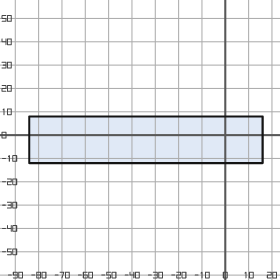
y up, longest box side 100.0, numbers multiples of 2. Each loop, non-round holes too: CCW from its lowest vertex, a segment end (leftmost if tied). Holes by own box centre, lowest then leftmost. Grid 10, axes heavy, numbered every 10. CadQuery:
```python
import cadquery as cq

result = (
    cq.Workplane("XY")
    .moveTo(-84.0, -12.0)
    .lineTo(16.0, -12.0)
    .lineTo(16.0, 8.0)
    .lineTo(-84.0, 8.0)
    .close()
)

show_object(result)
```